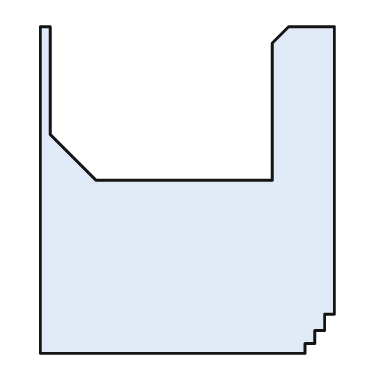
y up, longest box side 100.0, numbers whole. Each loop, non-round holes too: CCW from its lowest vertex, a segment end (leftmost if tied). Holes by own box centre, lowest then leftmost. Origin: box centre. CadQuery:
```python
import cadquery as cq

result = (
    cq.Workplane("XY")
    .moveTo(-45.0, -50.0)
    .lineTo(36.0, -50.0)
    .lineTo(36.0, -47.0)
    .lineTo(39.0, -47.0)
    .lineTo(39.0, -43.0)
    .lineTo(42.0, -43.0)
    .lineTo(42.0, -38.0)
    .lineTo(45.0, -38.0)
    .lineTo(45.0, 50.0)
    .lineTo(31.0, 50.0)
    .lineTo(26.0, 45.0)
    .lineTo(26.0, 3.0)
    .lineTo(-28.0, 3.0)
    .lineTo(-42.0, 17.0)
    .lineTo(-42.0, 50.0)
    .lineTo(-45.0, 50.0)
    .close()
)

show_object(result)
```